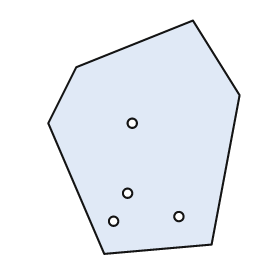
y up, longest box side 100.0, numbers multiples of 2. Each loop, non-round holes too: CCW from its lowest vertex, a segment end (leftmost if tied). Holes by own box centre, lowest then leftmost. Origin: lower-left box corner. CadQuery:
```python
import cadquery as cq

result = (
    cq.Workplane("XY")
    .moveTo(24.0, 0.0)
    .lineTo(70.0, 4.0)
    .lineTo(82.0, 68.0)
    .lineTo(62.0, 100.0)
    .lineTo(12.0, 80.0)
    .lineTo(0.0, 56.0)
    .close()
    .moveTo(28.0, 14.0)
    .circle(2.0)
    .moveTo(56.0, 16.0)
    .circle(2.0)
    .moveTo(34.0, 26.0)
    .circle(2.0)
    .moveTo(36.0, 56.0)
    .circle(2.0)
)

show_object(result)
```